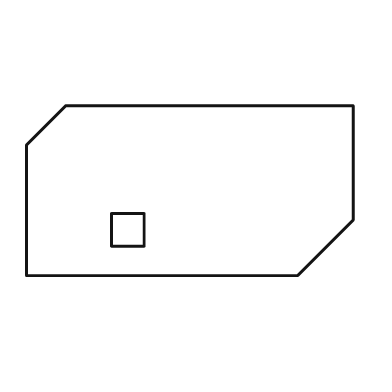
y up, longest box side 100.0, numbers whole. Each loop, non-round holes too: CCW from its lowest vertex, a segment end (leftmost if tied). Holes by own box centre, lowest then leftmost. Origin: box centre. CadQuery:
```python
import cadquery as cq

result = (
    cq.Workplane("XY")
    .moveTo(-50.0, -26.0)
    .lineTo(33.0, -26.0)
    .lineTo(50.0, -9.0)
    .lineTo(50.0, 26.0)
    .lineTo(-38.0, 26.0)
    .lineTo(-50.0, 14.0)
    .close()
    .moveTo(-24.0, -17.0)
    .lineTo(-14.0, -17.0)
    .lineTo(-14.0, -7.0)
    .lineTo(-24.0, -7.0)
    .close()
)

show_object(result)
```